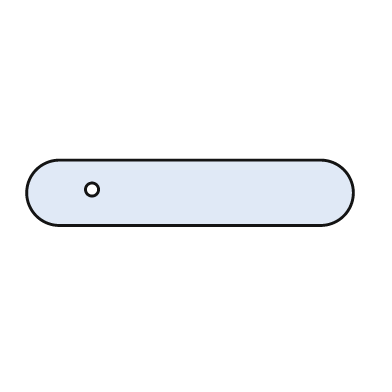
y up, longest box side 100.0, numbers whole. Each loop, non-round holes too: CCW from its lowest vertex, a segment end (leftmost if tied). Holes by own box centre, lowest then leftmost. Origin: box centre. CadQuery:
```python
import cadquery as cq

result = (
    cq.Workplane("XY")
    .moveTo(-40.0, -10.0)
    .lineTo(40.0, -10.0)
    .threePointArc((50.0, 0.0), (40.0, 10.0))
    .lineTo(-40.0, 10.0)
    .threePointArc((-50.0, 0.0), (-40.0, -10.0))
    .close()
    .moveTo(-30.0, 1.0)
    .circle(2.0)
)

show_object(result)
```